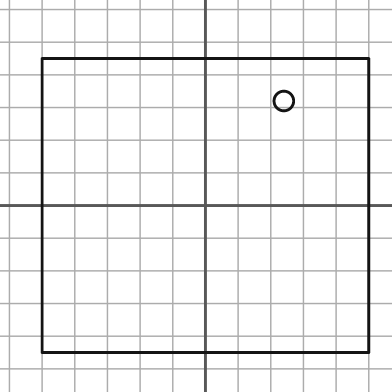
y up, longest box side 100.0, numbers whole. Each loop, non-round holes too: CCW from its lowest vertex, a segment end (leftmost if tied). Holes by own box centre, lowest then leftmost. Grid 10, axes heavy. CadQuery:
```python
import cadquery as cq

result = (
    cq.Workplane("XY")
    .moveTo(-50.0, -45.0)
    .lineTo(50.0, -45.0)
    .lineTo(50.0, 45.0)
    .lineTo(-50.0, 45.0)
    .close()
    .moveTo(24.0, 32.0)
    .circle(3.0)
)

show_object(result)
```